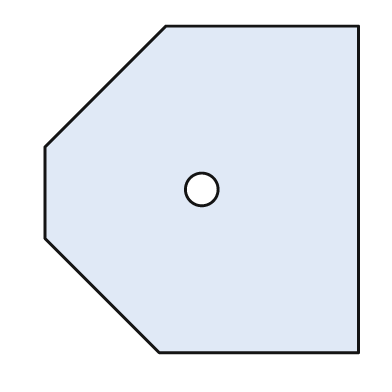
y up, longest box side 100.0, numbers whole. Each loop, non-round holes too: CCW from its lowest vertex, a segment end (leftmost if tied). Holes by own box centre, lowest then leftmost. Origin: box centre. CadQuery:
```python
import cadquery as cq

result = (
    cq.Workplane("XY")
    .moveTo(-13.0, -50.0)
    .lineTo(48.0, -50.0)
    .lineTo(48.0, 50.0)
    .lineTo(-11.0, 50.0)
    .lineTo(-48.0, 13.0)
    .lineTo(-48.0, -15.0)
    .close()
    .moveTo(0.0, 0.0)
    .circle(5.0)
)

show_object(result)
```